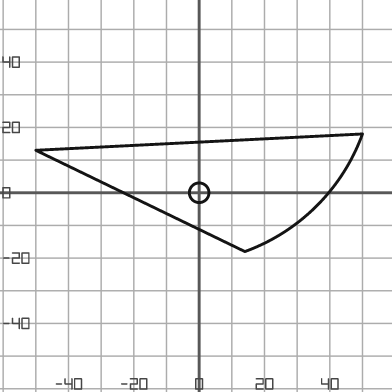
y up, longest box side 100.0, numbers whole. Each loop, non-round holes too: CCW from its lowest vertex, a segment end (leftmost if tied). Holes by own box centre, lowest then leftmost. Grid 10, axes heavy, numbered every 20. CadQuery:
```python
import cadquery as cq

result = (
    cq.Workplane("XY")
    .moveTo(14.0, -18.0)
    .threePointArc((36.0, -4.0), (50.0, 18.0))
    .lineTo(-50.0, 13.0)
    .close()
    .moveTo(0.0, 0.0)
    .circle(3.0)
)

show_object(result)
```